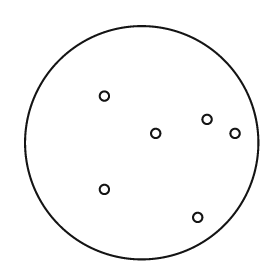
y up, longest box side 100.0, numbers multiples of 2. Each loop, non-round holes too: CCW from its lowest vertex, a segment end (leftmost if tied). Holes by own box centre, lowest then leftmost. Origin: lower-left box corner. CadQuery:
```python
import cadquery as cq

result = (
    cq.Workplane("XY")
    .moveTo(50.0, 50.0)
    .circle(50.0)
    .moveTo(74.0, 18.0)
    .circle(2.0)
    .moveTo(34.0, 30.0)
    .circle(2.0)
    .moveTo(56.0, 54.0)
    .circle(2.0)
    .moveTo(90.0, 54.0)
    .circle(2.0)
    .moveTo(78.0, 60.0)
    .circle(2.0)
    .moveTo(34.0, 70.0)
    .circle(2.0)
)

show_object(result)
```